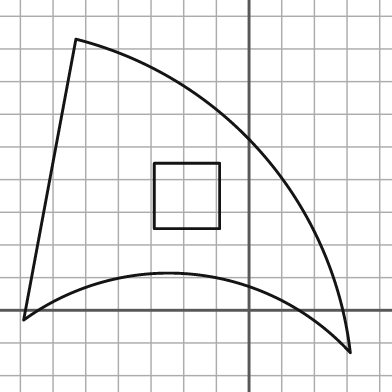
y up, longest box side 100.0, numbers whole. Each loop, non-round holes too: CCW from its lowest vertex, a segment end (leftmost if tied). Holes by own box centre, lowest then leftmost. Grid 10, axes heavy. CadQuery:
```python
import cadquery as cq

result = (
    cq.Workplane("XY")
    .moveTo(31.0, -13.0)
    .threePointArc((4.0, 48.0), (-53.0, 83.0))
    .lineTo(-69.0, -3.0)
    .threePointArc((-17.0, 11.0), (31.0, -13.0))
    .close()
    .moveTo(-29.0, 25.0)
    .lineTo(-9.0, 25.0)
    .lineTo(-9.0, 45.0)
    .lineTo(-29.0, 45.0)
    .close()
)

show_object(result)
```